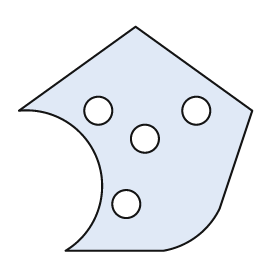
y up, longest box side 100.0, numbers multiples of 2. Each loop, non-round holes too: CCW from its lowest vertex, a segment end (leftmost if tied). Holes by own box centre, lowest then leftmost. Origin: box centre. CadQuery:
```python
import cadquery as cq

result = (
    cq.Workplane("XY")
    .moveTo(-30.0, -48.0)
    .lineTo(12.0, -48.0)
    .threePointArc((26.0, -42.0), (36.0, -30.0))
    .lineTo(50.0, 12.0)
    .lineTo(0.0, 48.0)
    .lineTo(-50.0, 12.0)
    .threePointArc((-16.0, -10.0), (-30.0, -48.0))
    .close()
    .moveTo(-4.0, -28.0)
    .circle(6.0)
    .moveTo(4.0, 0.0)
    .circle(6.0)
    .moveTo(-16.0, 12.0)
    .circle(6.0)
    .moveTo(26.0, 12.0)
    .circle(6.0)
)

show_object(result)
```